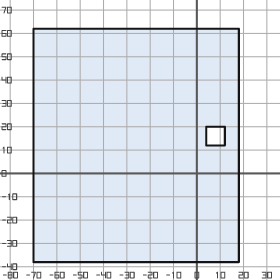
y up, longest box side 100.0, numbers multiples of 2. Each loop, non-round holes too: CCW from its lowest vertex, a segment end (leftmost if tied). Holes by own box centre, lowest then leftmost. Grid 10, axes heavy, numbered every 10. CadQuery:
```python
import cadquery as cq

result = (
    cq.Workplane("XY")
    .moveTo(-70.0, -38.0)
    .lineTo(18.0, -38.0)
    .lineTo(18.0, 62.0)
    .lineTo(-70.0, 62.0)
    .close()
    .moveTo(4.0, 12.0)
    .lineTo(12.0, 12.0)
    .lineTo(12.0, 20.0)
    .lineTo(4.0, 20.0)
    .close()
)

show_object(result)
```